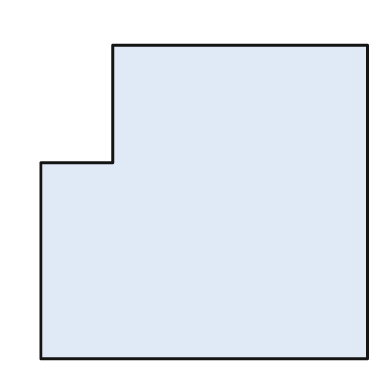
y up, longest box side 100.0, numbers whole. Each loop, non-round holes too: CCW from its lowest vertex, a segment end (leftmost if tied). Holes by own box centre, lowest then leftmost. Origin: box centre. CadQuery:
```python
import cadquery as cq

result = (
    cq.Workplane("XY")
    .moveTo(-50.0, -48.0)
    .lineTo(50.0, -48.0)
    .lineTo(50.0, 48.0)
    .lineTo(-28.0, 48.0)
    .lineTo(-28.0, 12.0)
    .lineTo(-50.0, 12.0)
    .close()
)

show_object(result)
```